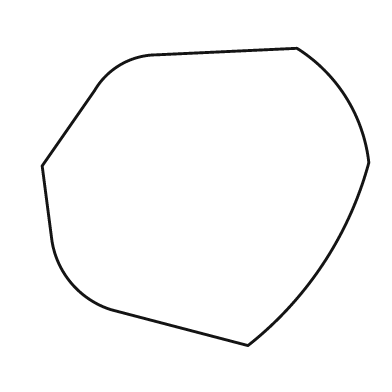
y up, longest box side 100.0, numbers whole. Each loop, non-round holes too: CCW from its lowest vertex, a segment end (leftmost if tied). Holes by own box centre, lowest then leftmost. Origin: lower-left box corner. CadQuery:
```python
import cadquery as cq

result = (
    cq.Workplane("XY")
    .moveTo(63.0, 0.0)
    .threePointArc((86.0, 25.0), (100.0, 56.0))
    .threePointArc((93.0, 76.0), (78.0, 91.0))
    .lineTo(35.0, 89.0)
    .threePointArc((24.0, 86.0), (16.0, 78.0))
    .lineTo(0.0, 55.0)
    .lineTo(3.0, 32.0)
    .threePointArc((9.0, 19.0), (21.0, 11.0))
    .close()
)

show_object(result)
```